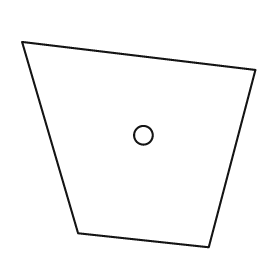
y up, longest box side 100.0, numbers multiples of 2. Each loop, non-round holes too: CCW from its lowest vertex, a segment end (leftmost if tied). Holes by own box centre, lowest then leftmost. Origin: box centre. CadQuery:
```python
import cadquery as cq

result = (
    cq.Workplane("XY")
    .moveTo(30.0, -44.0)
    .lineTo(50.0, 32.0)
    .lineTo(-50.0, 44.0)
    .lineTo(-26.0, -38.0)
    .close()
    .moveTo(2.0, 4.0)
    .circle(4.0)
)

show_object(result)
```